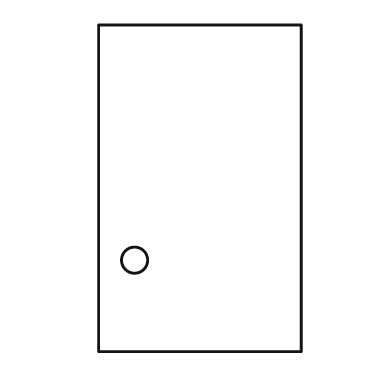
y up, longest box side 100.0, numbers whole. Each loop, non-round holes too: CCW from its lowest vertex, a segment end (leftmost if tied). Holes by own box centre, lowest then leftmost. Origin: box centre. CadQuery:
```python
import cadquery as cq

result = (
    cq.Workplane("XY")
    .moveTo(-31.0, -50.0)
    .lineTo(31.0, -50.0)
    .lineTo(31.0, 50.0)
    .lineTo(-31.0, 50.0)
    .close()
    .moveTo(-20.0, -22.0)
    .circle(4.0)
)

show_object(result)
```